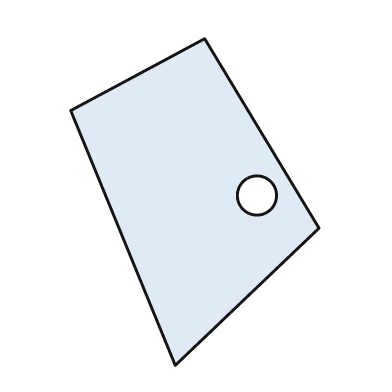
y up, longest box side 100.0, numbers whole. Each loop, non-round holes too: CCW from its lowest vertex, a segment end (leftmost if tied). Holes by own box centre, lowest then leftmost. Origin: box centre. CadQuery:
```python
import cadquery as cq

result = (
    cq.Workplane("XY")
    .moveTo(-6.0, -50.0)
    .lineTo(38.0, -8.0)
    .lineTo(3.0, 50.0)
    .lineTo(-38.0, 28.0)
    .close()
    .moveTo(19.0, 2.0)
    .circle(6.0)
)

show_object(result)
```